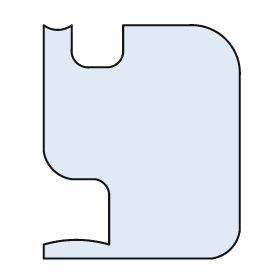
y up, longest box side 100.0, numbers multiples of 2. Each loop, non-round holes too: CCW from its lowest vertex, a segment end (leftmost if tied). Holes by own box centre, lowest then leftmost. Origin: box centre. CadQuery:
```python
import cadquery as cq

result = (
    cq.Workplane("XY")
    .moveTo(-42.0, -50.0)
    .lineTo(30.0, -50.0)
    .threePointArc((38.0, -46.0), (42.0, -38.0))
    .lineTo(42.0, 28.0)
    .threePointArc((36.0, 44.0), (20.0, 50.0))
    .lineTo(-8.0, 50.0)
    .lineTo(-8.0, 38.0)
    .threePointArc((-10.0, 34.0), (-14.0, 32.0))
    .lineTo(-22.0, 32.0)
    .threePointArc((-28.0, 34.0), (-30.0, 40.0))
    .lineTo(-30.0, 50.0)
    .threePointArc((-36.0, 48.0), (-42.0, 50.0))
    .lineTo(-42.0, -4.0)
    .threePointArc((-38.0, -12.0), (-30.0, -16.0))
    .lineTo(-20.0, -16.0)
    .threePointArc((-16.0, -18.0), (-14.0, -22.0))
    .lineTo(-14.0, -44.0)
    .threePointArc((-28.0, -42.0), (-42.0, -44.0))
    .close()
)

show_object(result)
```